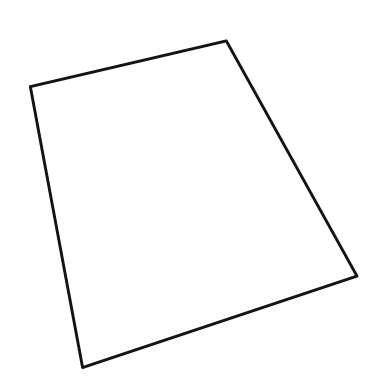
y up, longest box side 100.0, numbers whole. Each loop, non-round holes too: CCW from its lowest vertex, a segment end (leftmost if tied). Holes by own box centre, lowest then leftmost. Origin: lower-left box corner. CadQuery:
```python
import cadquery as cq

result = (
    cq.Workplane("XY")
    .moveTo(16.0, 0.0)
    .lineTo(100.0, 28.0)
    .lineTo(60.0, 100.0)
    .lineTo(0.0, 86.0)
    .close()
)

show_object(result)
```